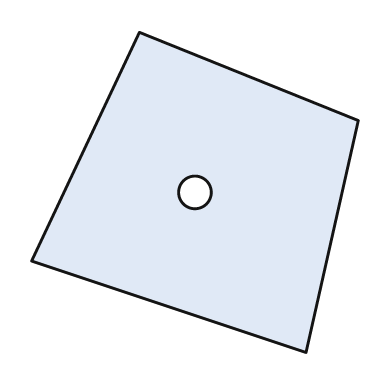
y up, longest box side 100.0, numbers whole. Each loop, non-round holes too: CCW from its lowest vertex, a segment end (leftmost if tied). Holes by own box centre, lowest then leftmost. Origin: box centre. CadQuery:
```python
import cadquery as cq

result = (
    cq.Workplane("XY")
    .moveTo(34.0, -49.0)
    .lineTo(50.0, 22.0)
    .lineTo(-17.0, 49.0)
    .lineTo(-50.0, -21.0)
    .close()
    .moveTo(0.0, 0.0)
    .circle(5.0)
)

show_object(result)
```